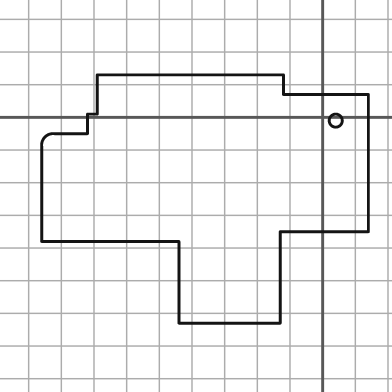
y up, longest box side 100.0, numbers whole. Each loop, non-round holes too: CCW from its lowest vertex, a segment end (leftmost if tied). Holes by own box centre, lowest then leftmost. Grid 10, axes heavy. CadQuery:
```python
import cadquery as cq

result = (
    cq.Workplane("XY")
    .moveTo(-44.0, -63.0)
    .lineTo(-13.0, -63.0)
    .lineTo(-13.0, -35.0)
    .lineTo(14.0, -35.0)
    .lineTo(14.0, 7.0)
    .lineTo(-12.0, 7.0)
    .lineTo(-12.0, 13.0)
    .lineTo(-69.0, 13.0)
    .lineTo(-69.0, 1.0)
    .lineTo(-72.0, 1.0)
    .lineTo(-72.0, -5.0)
    .lineTo(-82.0, -5.0)
    .threePointArc((-85.0, -6.0), (-86.0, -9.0))
    .lineTo(-86.0, -38.0)
    .lineTo(-44.0, -38.0)
    .close()
    .moveTo(4.0, -1.0)
    .circle(2.0)
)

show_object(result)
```